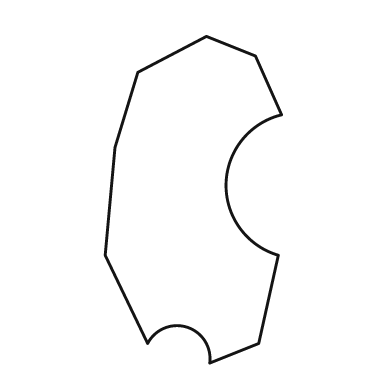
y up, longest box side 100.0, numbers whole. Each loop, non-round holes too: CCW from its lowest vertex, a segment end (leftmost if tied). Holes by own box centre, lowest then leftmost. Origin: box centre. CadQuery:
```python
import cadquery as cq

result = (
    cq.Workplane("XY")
    .moveTo(5.0, -50.0)
    .lineTo(20.0, -44.0)
    .lineTo(26.0, -17.0)
    .threePointArc((10.0, 5.0), (27.0, 26.0))
    .lineTo(19.0, 44.0)
    .lineTo(4.0, 50.0)
    .lineTo(-17.0, 39.0)
    .lineTo(-24.0, 16.0)
    .lineTo(-27.0, -17.0)
    .lineTo(-14.0, -44.0)
    .threePointArc((-2.0, -39.0), (5.0, -50.0))
    .close()
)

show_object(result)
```